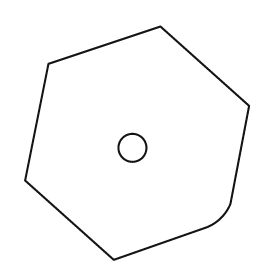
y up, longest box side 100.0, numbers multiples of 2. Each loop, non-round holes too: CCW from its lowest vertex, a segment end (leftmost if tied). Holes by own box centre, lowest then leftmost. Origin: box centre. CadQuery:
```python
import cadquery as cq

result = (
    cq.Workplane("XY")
    .moveTo(-10.0, -50.0)
    .lineTo(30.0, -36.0)
    .threePointArc((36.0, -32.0), (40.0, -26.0))
    .lineTo(48.0, 16.0)
    .lineTo(10.0, 50.0)
    .lineTo(-38.0, 34.0)
    .lineTo(-48.0, -16.0)
    .close()
    .moveTo(-2.0, -2.0)
    .circle(6.0)
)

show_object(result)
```